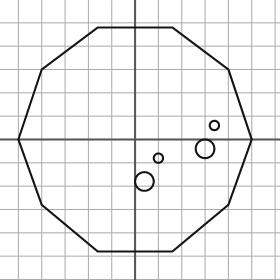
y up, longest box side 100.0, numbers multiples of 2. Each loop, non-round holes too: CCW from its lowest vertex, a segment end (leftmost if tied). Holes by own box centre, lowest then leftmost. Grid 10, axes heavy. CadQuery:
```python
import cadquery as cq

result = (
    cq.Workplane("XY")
    .moveTo(-16.0, -48.0)
    .lineTo(16.0, -48.0)
    .lineTo(40.0, -28.0)
    .lineTo(50.0, 0.0)
    .lineTo(40.0, 30.0)
    .lineTo(16.0, 48.0)
    .lineTo(-16.0, 48.0)
    .lineTo(-40.0, 30.0)
    .lineTo(-50.0, 0.0)
    .lineTo(-40.0, -28.0)
    .close()
    .moveTo(4.0, -18.0)
    .circle(4.0)
    .moveTo(10.0, -8.0)
    .circle(2.0)
    .moveTo(30.0, -4.0)
    .circle(4.0)
    .moveTo(34.0, 6.0)
    .circle(2.0)
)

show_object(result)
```